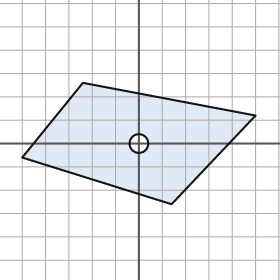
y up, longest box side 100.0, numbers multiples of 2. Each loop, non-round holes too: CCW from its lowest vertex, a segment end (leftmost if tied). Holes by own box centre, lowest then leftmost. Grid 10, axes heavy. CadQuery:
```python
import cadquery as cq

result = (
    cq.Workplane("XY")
    .moveTo(14.0, -26.0)
    .lineTo(50.0, 12.0)
    .lineTo(-24.0, 26.0)
    .lineTo(-50.0, -6.0)
    .close()
    .moveTo(0.0, 0.0)
    .circle(4.0)
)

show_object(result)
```